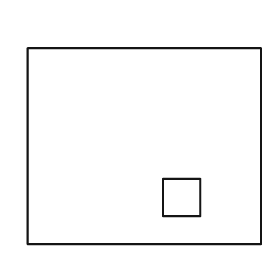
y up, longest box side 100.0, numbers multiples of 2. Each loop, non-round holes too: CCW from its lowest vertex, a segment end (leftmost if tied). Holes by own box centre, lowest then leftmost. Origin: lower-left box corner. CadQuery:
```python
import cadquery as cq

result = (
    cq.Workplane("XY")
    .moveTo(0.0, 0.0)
    .lineTo(100.0, 0.0)
    .lineTo(100.0, 84.0)
    .lineTo(0.0, 84.0)
    .close()
    .moveTo(58.0, 12.0)
    .lineTo(74.0, 12.0)
    .lineTo(74.0, 28.0)
    .lineTo(58.0, 28.0)
    .close()
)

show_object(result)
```